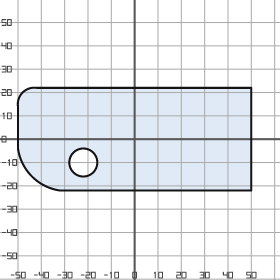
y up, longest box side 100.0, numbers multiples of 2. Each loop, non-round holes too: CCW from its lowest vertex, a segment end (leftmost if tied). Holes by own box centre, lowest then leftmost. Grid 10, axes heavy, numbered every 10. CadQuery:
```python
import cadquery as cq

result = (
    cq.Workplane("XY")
    .moveTo(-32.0, -22.0)
    .lineTo(50.0, -22.0)
    .lineTo(50.0, 22.0)
    .lineTo(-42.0, 22.0)
    .threePointArc((-48.0, 20.0), (-50.0, 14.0))
    .lineTo(-50.0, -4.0)
    .threePointArc((-44.0, -16.0), (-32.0, -22.0))
    .close()
    .moveTo(-22.0, -10.0)
    .circle(6.0)
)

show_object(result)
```